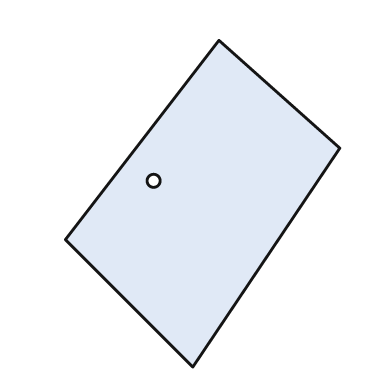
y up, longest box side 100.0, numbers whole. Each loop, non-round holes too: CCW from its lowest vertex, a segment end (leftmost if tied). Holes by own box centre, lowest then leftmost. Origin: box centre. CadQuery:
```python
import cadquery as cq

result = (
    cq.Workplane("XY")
    .moveTo(-3.0, -50.0)
    .lineTo(42.0, 17.0)
    .lineTo(5.0, 50.0)
    .lineTo(-42.0, -11.0)
    .close()
    .moveTo(-15.0, 7.0)
    .circle(2.0)
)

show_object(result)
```